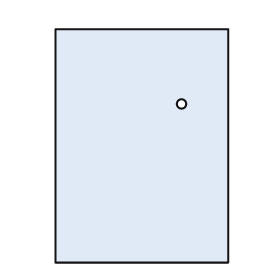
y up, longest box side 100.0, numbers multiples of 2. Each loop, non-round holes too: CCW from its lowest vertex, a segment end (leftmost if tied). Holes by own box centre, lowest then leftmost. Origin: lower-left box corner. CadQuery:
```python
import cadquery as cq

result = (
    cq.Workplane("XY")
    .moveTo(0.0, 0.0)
    .lineTo(74.0, 0.0)
    .lineTo(74.0, 100.0)
    .lineTo(0.0, 100.0)
    .close()
    .moveTo(54.0, 68.0)
    .circle(2.0)
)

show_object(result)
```